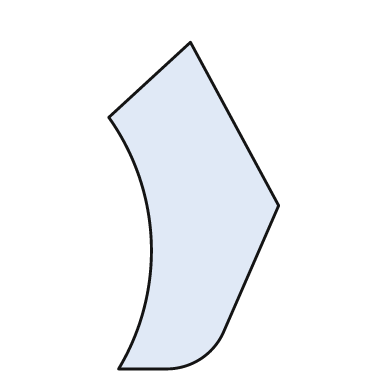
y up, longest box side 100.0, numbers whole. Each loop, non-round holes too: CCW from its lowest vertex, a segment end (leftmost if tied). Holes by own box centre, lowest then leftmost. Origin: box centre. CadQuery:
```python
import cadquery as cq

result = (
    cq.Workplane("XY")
    .moveTo(-23.0, -50.0)
    .lineTo(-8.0, -50.0)
    .threePointArc((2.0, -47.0), (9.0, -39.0))
    .lineTo(26.0, 0.0)
    .lineTo(-1.0, 50.0)
    .lineTo(-26.0, 27.0)
    .threePointArc((-13.0, -11.0), (-23.0, -50.0))
    .close()
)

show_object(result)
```